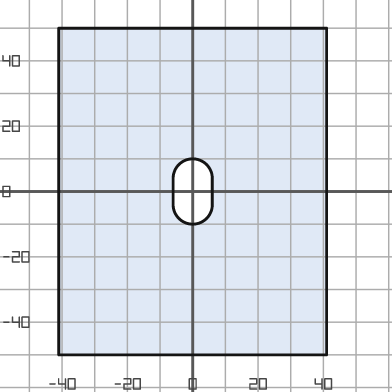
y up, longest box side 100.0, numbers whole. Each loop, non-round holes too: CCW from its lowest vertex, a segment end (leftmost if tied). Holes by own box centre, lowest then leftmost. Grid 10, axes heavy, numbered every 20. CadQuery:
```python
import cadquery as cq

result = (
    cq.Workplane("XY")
    .moveTo(-41.0, -50.0)
    .lineTo(41.0, -50.0)
    .lineTo(41.0, 50.0)
    .lineTo(-41.0, 50.0)
    .close()
    .moveTo(-6.0, -4.0)
    .threePointArc((0.0, -10.0), (6.0, -4.0))
    .lineTo(6.0, 4.0)
    .threePointArc((0.0, 10.0), (-6.0, 4.0))
    .close()
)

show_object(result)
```